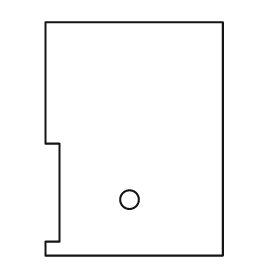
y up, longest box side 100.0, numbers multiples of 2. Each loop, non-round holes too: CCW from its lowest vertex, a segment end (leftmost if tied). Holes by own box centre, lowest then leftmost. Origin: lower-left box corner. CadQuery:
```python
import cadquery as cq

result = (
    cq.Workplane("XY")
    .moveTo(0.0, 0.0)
    .lineTo(76.0, 0.0)
    .lineTo(76.0, 100.0)
    .lineTo(0.0, 100.0)
    .lineTo(0.0, 48.0)
    .lineTo(6.0, 48.0)
    .lineTo(6.0, 6.0)
    .lineTo(0.0, 6.0)
    .close()
    .moveTo(36.0, 24.0)
    .circle(4.0)
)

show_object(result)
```